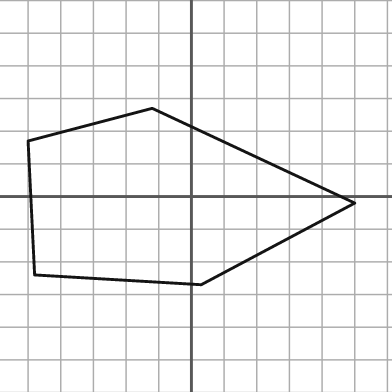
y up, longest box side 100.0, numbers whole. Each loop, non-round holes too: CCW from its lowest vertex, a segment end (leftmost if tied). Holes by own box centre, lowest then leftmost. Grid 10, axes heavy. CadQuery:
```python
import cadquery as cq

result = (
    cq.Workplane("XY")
    .moveTo(3.0, -27.0)
    .lineTo(50.0, -2.0)
    .lineTo(-12.0, 27.0)
    .lineTo(-50.0, 17.0)
    .lineTo(-48.0, -24.0)
    .close()
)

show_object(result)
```